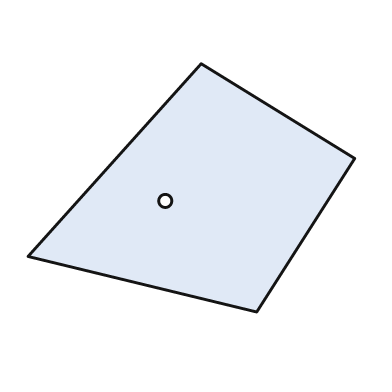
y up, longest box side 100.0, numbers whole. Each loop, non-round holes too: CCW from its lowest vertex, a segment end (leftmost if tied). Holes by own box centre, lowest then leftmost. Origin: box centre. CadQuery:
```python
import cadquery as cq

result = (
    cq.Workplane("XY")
    .moveTo(20.0, -38.0)
    .lineTo(50.0, 9.0)
    .lineTo(3.0, 38.0)
    .lineTo(-50.0, -21.0)
    .close()
    .moveTo(-8.0, -4.0)
    .circle(2.0)
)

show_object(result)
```